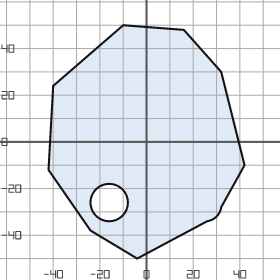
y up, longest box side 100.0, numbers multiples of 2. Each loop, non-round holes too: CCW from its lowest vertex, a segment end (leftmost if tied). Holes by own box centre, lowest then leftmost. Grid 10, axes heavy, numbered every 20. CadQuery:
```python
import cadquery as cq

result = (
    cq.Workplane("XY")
    .moveTo(-4.0, -50.0)
    .lineTo(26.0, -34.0)
    .threePointArc((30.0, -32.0), (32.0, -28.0))
    .lineTo(42.0, -10.0)
    .lineTo(32.0, 30.0)
    .lineTo(16.0, 48.0)
    .lineTo(-10.0, 50.0)
    .lineTo(-40.0, 24.0)
    .lineTo(-42.0, -12.0)
    .lineTo(-24.0, -38.0)
    .close()
    .moveTo(-16.0, -26.0)
    .circle(8.0)
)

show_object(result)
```